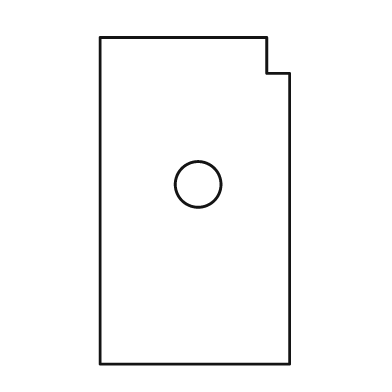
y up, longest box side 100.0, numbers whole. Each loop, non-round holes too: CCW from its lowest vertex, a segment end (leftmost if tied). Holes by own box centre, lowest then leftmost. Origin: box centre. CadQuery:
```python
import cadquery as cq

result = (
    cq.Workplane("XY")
    .moveTo(-29.0, -50.0)
    .lineTo(29.0, -50.0)
    .lineTo(29.0, 39.0)
    .lineTo(22.0, 39.0)
    .lineTo(22.0, 50.0)
    .lineTo(-29.0, 50.0)
    .close()
    .moveTo(1.0, 5.0)
    .circle(7.0)
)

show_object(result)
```